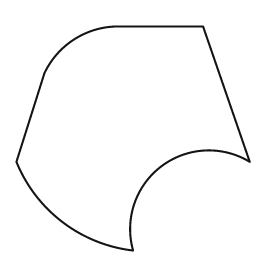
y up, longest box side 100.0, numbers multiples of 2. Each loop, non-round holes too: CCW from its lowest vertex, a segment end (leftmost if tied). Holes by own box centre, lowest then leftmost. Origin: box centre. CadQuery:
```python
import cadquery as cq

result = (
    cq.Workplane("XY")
    .moveTo(0.0, -48.0)
    .threePointArc((12.0, -12.0), (50.0, -10.0))
    .lineTo(30.0, 48.0)
    .lineTo(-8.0, 48.0)
    .threePointArc((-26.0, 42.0), (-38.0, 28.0))
    .lineTo(-50.0, -10.0)
    .threePointArc((-30.0, -36.0), (0.0, -48.0))
    .close()
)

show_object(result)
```